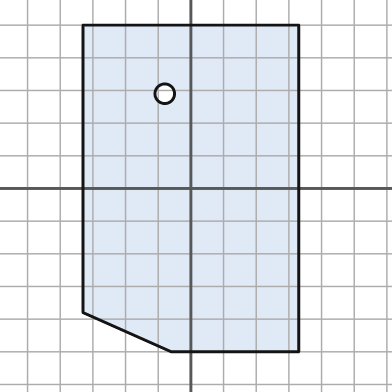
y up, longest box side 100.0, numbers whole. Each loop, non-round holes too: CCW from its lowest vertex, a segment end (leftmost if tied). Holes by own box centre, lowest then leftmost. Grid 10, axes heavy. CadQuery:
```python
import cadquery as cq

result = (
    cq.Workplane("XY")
    .moveTo(-6.0, -50.0)
    .lineTo(33.0, -50.0)
    .lineTo(33.0, 50.0)
    .lineTo(-33.0, 50.0)
    .lineTo(-33.0, -38.0)
    .close()
    .moveTo(-8.0, 29.0)
    .circle(3.0)
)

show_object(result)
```